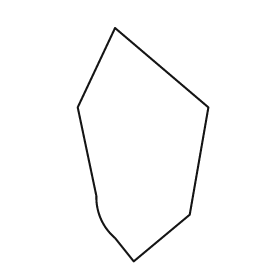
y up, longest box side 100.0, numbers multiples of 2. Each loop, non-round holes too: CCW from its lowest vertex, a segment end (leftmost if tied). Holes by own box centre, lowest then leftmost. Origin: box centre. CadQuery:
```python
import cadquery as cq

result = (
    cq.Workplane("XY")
    .moveTo(-4.0, -50.0)
    .lineTo(20.0, -30.0)
    .lineTo(28.0, 16.0)
    .lineTo(-12.0, 50.0)
    .lineTo(-28.0, 16.0)
    .lineTo(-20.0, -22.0)
    .threePointArc((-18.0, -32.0), (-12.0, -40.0))
    .close()
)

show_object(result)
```